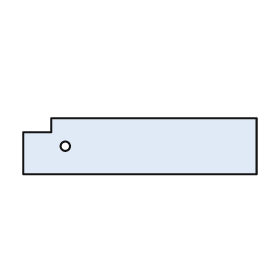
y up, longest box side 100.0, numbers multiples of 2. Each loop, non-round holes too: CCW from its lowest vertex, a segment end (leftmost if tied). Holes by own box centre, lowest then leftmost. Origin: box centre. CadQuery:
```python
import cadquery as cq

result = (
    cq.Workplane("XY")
    .moveTo(-50.0, -12.0)
    .lineTo(50.0, -12.0)
    .lineTo(50.0, 12.0)
    .lineTo(-38.0, 12.0)
    .lineTo(-38.0, 6.0)
    .lineTo(-50.0, 6.0)
    .close()
    .moveTo(-32.0, 0.0)
    .circle(2.0)
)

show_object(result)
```